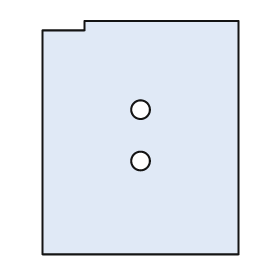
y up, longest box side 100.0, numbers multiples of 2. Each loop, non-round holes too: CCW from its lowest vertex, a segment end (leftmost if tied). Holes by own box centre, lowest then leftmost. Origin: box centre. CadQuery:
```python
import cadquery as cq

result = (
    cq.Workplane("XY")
    .moveTo(-42.0, -50.0)
    .lineTo(42.0, -50.0)
    .lineTo(42.0, 50.0)
    .lineTo(-24.0, 50.0)
    .lineTo(-24.0, 46.0)
    .lineTo(-42.0, 46.0)
    .close()
    .moveTo(0.0, -10.0)
    .circle(4.0)
    .moveTo(0.0, 12.0)
    .circle(4.0)
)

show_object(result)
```